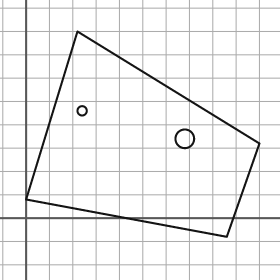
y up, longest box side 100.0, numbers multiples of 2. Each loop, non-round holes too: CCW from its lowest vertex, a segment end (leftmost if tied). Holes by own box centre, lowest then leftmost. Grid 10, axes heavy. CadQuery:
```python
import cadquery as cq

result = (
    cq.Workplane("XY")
    .moveTo(86.0, -8.0)
    .lineTo(100.0, 32.0)
    .lineTo(22.0, 80.0)
    .lineTo(0.0, 8.0)
    .close()
    .moveTo(68.0, 34.0)
    .circle(4.0)
    .moveTo(24.0, 46.0)
    .circle(2.0)
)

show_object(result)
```